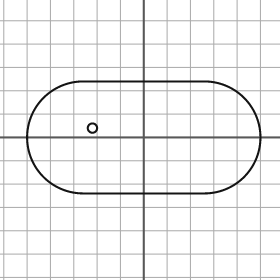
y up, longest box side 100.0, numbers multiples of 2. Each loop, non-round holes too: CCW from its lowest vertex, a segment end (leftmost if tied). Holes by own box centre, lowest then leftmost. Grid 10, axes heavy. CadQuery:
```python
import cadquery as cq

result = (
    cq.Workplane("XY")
    .moveTo(-26.0, -24.0)
    .lineTo(26.0, -24.0)
    .threePointArc((50.0, 0.0), (26.0, 24.0))
    .lineTo(-26.0, 24.0)
    .threePointArc((-50.0, 0.0), (-26.0, -24.0))
    .close()
    .moveTo(-22.0, 4.0)
    .circle(2.0)
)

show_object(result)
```